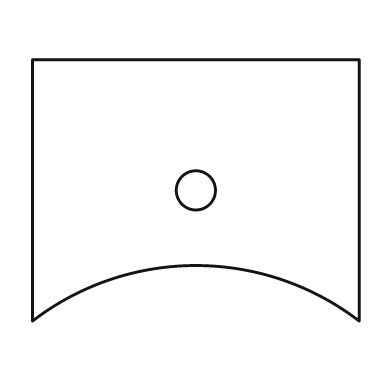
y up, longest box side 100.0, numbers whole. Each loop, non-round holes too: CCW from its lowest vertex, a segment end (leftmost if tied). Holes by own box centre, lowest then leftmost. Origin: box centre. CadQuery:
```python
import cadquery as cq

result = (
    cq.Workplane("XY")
    .moveTo(-50.0, -40.0)
    .threePointArc((0.0, -23.0), (50.0, -40.0))
    .lineTo(50.0, 40.0)
    .lineTo(-50.0, 40.0)
    .close()
    .moveTo(0.0, 0.0)
    .circle(6.0)
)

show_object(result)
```